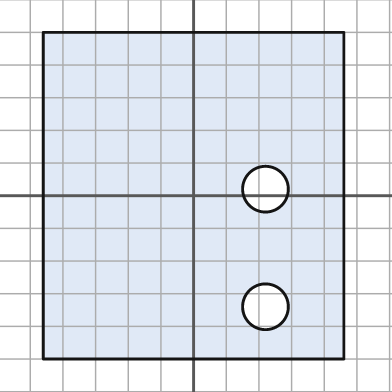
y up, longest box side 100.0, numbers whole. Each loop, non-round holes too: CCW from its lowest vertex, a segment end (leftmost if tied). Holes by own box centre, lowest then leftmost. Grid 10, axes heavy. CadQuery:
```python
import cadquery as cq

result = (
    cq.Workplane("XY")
    .moveTo(-46.0, -50.0)
    .lineTo(46.0, -50.0)
    .lineTo(46.0, 50.0)
    .lineTo(-46.0, 50.0)
    .close()
    .moveTo(22.0, -34.0)
    .circle(7.0)
    .moveTo(22.0, 2.0)
    .circle(7.0)
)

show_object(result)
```